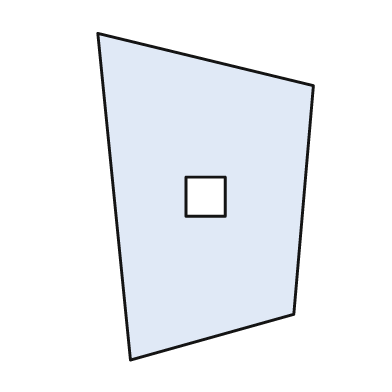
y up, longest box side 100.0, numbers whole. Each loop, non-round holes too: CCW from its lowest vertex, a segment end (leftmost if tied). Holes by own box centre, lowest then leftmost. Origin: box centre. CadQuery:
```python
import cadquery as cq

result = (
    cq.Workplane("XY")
    .moveTo(-23.0, -50.0)
    .lineTo(27.0, -36.0)
    .lineTo(33.0, 34.0)
    .lineTo(-33.0, 50.0)
    .close()
    .moveTo(-6.0, -6.0)
    .lineTo(6.0, -6.0)
    .lineTo(6.0, 6.0)
    .lineTo(-6.0, 6.0)
    .close()
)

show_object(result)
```